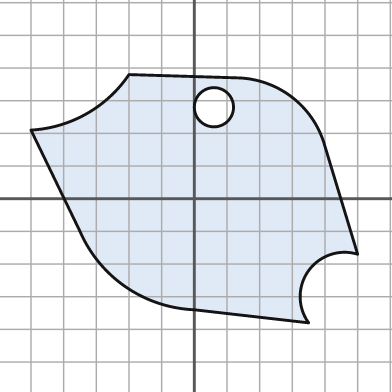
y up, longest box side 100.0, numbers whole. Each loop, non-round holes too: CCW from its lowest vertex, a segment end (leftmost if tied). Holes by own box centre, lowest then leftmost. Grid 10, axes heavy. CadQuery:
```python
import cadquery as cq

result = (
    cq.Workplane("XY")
    .moveTo(35.0, -38.0)
    .threePointArc((35.0, -22.0), (50.0, -17.0))
    .lineTo(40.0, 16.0)
    .threePointArc((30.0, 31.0), (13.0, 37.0))
    .lineTo(-20.0, 38.0)
    .threePointArc((-33.0, 26.0), (-50.0, 21.0))
    .lineTo(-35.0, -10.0)
    .threePointArc((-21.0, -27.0), (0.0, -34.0))
    .close()
    .moveTo(6.0, 28.0)
    .circle(6.0)
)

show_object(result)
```